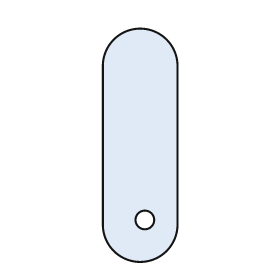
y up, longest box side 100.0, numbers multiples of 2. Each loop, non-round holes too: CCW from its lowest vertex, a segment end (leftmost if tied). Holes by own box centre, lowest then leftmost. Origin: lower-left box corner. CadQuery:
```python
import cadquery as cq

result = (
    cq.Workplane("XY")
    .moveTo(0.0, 16.0)
    .threePointArc((16.0, 0.0), (32.0, 16.0))
    .lineTo(32.0, 84.0)
    .threePointArc((16.0, 100.0), (0.0, 84.0))
    .close()
    .moveTo(18.0, 18.0)
    .circle(4.0)
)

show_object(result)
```